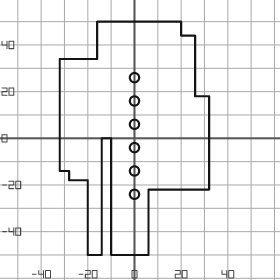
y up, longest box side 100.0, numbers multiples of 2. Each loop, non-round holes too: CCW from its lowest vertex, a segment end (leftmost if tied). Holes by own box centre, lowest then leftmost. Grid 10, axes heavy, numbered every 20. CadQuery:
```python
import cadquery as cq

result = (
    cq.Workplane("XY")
    .moveTo(-20.0, -50.0)
    .lineTo(-14.0, -50.0)
    .lineTo(-14.0, 0.0)
    .lineTo(-10.0, 0.0)
    .lineTo(-10.0, -50.0)
    .lineTo(6.0, -50.0)
    .lineTo(6.0, -22.0)
    .lineTo(32.0, -22.0)
    .lineTo(32.0, 18.0)
    .lineTo(26.0, 18.0)
    .lineTo(26.0, 44.0)
    .lineTo(20.0, 44.0)
    .lineTo(20.0, 50.0)
    .lineTo(-16.0, 50.0)
    .lineTo(-16.0, 34.0)
    .lineTo(-32.0, 34.0)
    .lineTo(-32.0, -14.0)
    .lineTo(-28.0, -14.0)
    .lineTo(-28.0, -18.0)
    .lineTo(-20.0, -18.0)
    .close()
    .moveTo(0.0, -24.0)
    .circle(2.0)
    .moveTo(0.0, -14.0)
    .circle(2.0)
    .moveTo(0.0, -4.0)
    .circle(2.0)
    .moveTo(0.0, 6.0)
    .circle(2.0)
    .moveTo(0.0, 16.0)
    .circle(2.0)
    .moveTo(0.0, 26.0)
    .circle(2.0)
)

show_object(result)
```